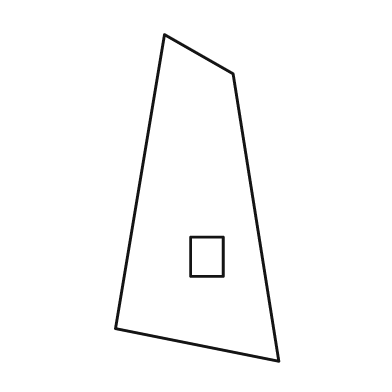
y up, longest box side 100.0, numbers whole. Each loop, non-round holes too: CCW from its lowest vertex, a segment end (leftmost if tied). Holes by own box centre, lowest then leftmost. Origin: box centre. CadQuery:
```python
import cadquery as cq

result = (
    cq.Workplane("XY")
    .moveTo(25.0, -50.0)
    .lineTo(11.0, 38.0)
    .lineTo(-10.0, 50.0)
    .lineTo(-25.0, -40.0)
    .close()
    .moveTo(-2.0, -24.0)
    .lineTo(8.0, -24.0)
    .lineTo(8.0, -12.0)
    .lineTo(-2.0, -12.0)
    .close()
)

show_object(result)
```